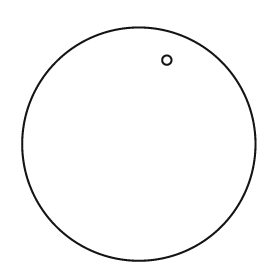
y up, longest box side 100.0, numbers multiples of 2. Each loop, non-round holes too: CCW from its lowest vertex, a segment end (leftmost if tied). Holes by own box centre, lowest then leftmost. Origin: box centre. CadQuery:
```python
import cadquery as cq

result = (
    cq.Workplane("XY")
    .moveTo(0.0, 0.0)
    .circle(50.0)
    .moveTo(12.0, 36.0)
    .circle(2.0)
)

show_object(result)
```